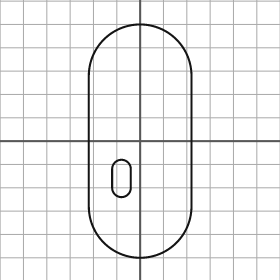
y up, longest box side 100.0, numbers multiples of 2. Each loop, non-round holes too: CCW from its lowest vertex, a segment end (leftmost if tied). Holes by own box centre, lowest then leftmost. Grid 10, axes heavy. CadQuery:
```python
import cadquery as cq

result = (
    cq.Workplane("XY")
    .moveTo(-22.0, -28.0)
    .threePointArc((0.0, -50.0), (22.0, -28.0))
    .lineTo(22.0, 28.0)
    .threePointArc((0.0, 50.0), (-22.0, 28.0))
    .close()
    .moveTo(-12.0, -20.0)
    .threePointArc((-8.0, -24.0), (-4.0, -20.0))
    .lineTo(-4.0, -12.0)
    .threePointArc((-8.0, -8.0), (-12.0, -12.0))
    .close()
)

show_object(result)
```